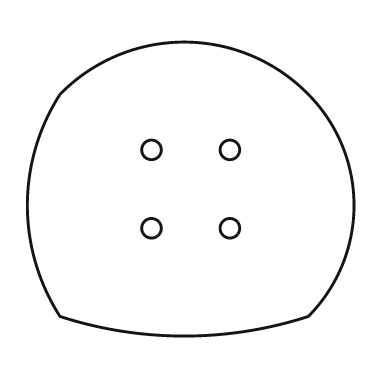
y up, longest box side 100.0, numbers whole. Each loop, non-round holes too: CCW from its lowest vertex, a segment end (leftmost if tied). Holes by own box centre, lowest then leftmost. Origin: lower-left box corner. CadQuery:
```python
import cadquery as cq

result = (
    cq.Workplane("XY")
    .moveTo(10.0, 6.0)
    .threePointArc((48.0, 0.0), (86.0, 6.0))
    .threePointArc((100.0, 40.0), (86.0, 74.0))
    .threePointArc((48.0, 90.0), (10.0, 74.0))
    .threePointArc((0.0, 40.0), (10.0, 6.0))
    .close()
    .moveTo(38.0, 33.0)
    .circle(3.0)
    .moveTo(62.0, 33.0)
    .circle(3.0)
    .moveTo(38.0, 57.0)
    .circle(3.0)
    .moveTo(62.0, 57.0)
    .circle(3.0)
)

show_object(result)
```